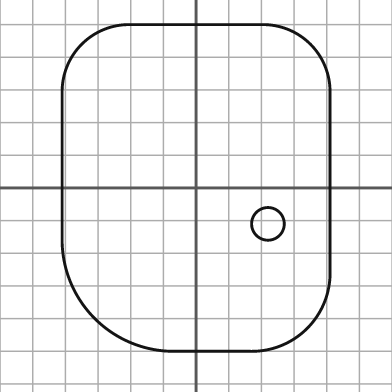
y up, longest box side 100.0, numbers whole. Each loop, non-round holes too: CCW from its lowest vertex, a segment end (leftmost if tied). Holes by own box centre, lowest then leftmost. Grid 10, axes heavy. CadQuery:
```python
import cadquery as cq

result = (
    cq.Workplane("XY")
    .moveTo(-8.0, -50.0)
    .lineTo(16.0, -50.0)
    .threePointArc((34.0, -43.0), (41.0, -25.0))
    .lineTo(41.0, 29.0)
    .threePointArc((35.0, 44.0), (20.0, 50.0))
    .lineTo(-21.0, 50.0)
    .threePointArc((-35.0, 44.0), (-41.0, 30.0))
    .lineTo(-41.0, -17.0)
    .threePointArc((-31.0, -40.0), (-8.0, -50.0))
    .close()
    .moveTo(22.0, -11.0)
    .circle(5.0)
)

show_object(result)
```